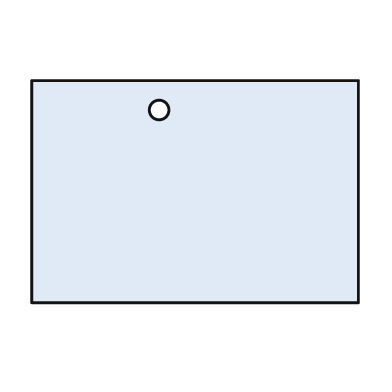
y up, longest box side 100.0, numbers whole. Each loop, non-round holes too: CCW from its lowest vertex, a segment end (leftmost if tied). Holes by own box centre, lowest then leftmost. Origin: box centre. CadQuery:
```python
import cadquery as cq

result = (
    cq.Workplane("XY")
    .moveTo(-50.0, -34.0)
    .lineTo(50.0, -34.0)
    .lineTo(50.0, 34.0)
    .lineTo(-50.0, 34.0)
    .close()
    .moveTo(-11.0, 25.0)
    .circle(3.0)
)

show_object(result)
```